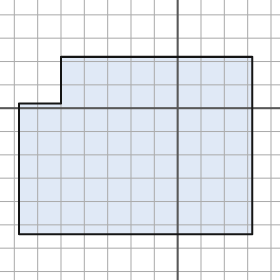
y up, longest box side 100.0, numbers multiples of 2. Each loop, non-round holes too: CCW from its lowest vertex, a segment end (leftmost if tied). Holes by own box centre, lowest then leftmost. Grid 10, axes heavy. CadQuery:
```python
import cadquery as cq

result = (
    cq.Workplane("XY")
    .moveTo(-68.0, -54.0)
    .lineTo(32.0, -54.0)
    .lineTo(32.0, 22.0)
    .lineTo(-50.0, 22.0)
    .lineTo(-50.0, 2.0)
    .lineTo(-68.0, 2.0)
    .close()
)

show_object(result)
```